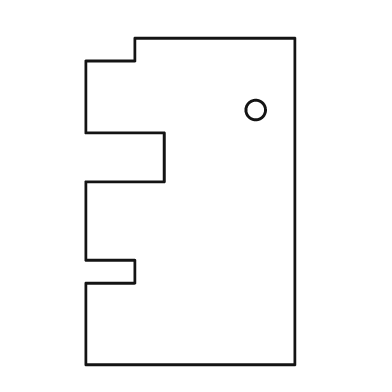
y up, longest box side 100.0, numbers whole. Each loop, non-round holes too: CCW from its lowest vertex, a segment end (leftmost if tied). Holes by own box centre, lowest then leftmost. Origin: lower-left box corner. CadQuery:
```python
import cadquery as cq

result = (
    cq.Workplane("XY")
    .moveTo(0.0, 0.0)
    .lineTo(64.0, 0.0)
    .lineTo(64.0, 100.0)
    .lineTo(15.0, 100.0)
    .lineTo(15.0, 93.0)
    .lineTo(0.0, 93.0)
    .lineTo(0.0, 71.0)
    .lineTo(24.0, 71.0)
    .lineTo(24.0, 56.0)
    .lineTo(0.0, 56.0)
    .lineTo(0.0, 32.0)
    .lineTo(15.0, 32.0)
    .lineTo(15.0, 25.0)
    .lineTo(0.0, 25.0)
    .close()
    .moveTo(52.0, 78.0)
    .circle(3.0)
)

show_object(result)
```